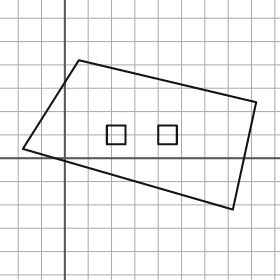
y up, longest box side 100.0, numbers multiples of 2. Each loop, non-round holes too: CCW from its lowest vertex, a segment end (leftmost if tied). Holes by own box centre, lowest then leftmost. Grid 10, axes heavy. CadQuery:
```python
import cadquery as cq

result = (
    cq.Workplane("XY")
    .moveTo(72.0, -22.0)
    .lineTo(82.0, 24.0)
    .lineTo(6.0, 42.0)
    .lineTo(-18.0, 4.0)
    .close()
    .moveTo(18.0, 6.0)
    .lineTo(26.0, 6.0)
    .lineTo(26.0, 14.0)
    .lineTo(18.0, 14.0)
    .close()
    .moveTo(40.0, 6.0)
    .lineTo(48.0, 6.0)
    .lineTo(48.0, 14.0)
    .lineTo(40.0, 14.0)
    .close()
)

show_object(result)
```